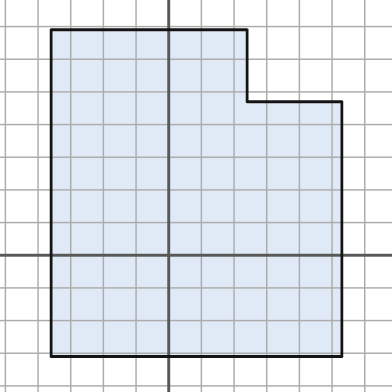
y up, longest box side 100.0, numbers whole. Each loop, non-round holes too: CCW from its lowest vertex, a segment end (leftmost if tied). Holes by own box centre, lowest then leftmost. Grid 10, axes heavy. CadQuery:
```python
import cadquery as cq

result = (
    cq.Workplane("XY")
    .moveTo(-36.0, -31.0)
    .lineTo(53.0, -31.0)
    .lineTo(53.0, 47.0)
    .lineTo(24.0, 47.0)
    .lineTo(24.0, 69.0)
    .lineTo(-36.0, 69.0)
    .close()
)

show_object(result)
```